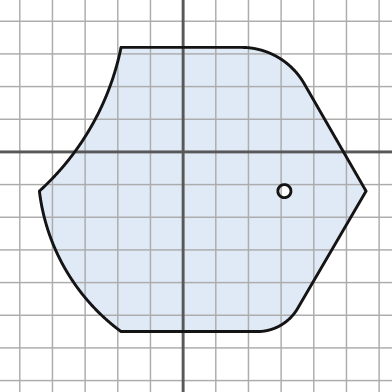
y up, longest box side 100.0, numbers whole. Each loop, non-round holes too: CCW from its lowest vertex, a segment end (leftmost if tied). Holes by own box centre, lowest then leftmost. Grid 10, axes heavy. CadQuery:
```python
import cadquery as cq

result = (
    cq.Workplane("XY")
    .moveTo(-19.0, -55.0)
    .lineTo(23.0, -55.0)
    .threePointArc((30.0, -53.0), (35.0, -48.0))
    .lineTo(56.0, -12.0)
    .lineTo(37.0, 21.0)
    .threePointArc((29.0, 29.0), (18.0, 32.0))
    .lineTo(-19.0, 32.0)
    .threePointArc((-28.0, 8.0), (-44.0, -12.0))
    .threePointArc((-36.0, -36.0), (-19.0, -55.0))
    .close()
    .moveTo(31.0, -12.0)
    .circle(2.0)
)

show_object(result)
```